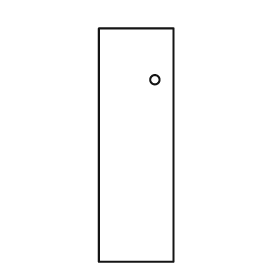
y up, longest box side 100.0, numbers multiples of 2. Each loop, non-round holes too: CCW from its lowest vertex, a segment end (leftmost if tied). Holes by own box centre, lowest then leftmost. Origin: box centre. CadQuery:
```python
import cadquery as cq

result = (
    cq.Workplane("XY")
    .moveTo(-16.0, -50.0)
    .lineTo(16.0, -50.0)
    .lineTo(16.0, 50.0)
    .lineTo(-16.0, 50.0)
    .close()
    .moveTo(8.0, 28.0)
    .circle(2.0)
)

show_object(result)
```